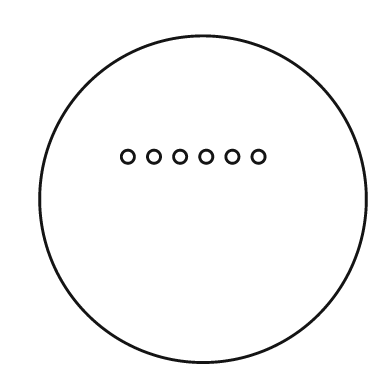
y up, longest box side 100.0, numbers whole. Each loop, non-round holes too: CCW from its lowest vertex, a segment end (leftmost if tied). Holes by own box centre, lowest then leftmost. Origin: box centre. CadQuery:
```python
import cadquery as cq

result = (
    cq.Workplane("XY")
    .moveTo(0.0, 0.0)
    .circle(50.0)
    .moveTo(-23.0, 13.0)
    .circle(2.0)
    .moveTo(-15.0, 13.0)
    .circle(2.0)
    .moveTo(-7.0, 13.0)
    .circle(2.0)
    .moveTo(1.0, 13.0)
    .circle(2.0)
    .moveTo(9.0, 13.0)
    .circle(2.0)
    .moveTo(17.0, 13.0)
    .circle(2.0)
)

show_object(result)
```